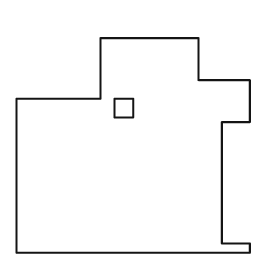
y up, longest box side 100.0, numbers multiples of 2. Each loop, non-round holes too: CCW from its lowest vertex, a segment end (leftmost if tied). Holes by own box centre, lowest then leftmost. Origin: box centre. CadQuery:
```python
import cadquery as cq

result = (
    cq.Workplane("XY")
    .moveTo(-50.0, -46.0)
    .lineTo(50.0, -46.0)
    .lineTo(50.0, -42.0)
    .lineTo(38.0, -42.0)
    .lineTo(38.0, 10.0)
    .lineTo(50.0, 10.0)
    .lineTo(50.0, 28.0)
    .lineTo(28.0, 28.0)
    .lineTo(28.0, 46.0)
    .lineTo(-14.0, 46.0)
    .lineTo(-14.0, 20.0)
    .lineTo(-50.0, 20.0)
    .close()
    .moveTo(-8.0, 12.0)
    .lineTo(0.0, 12.0)
    .lineTo(0.0, 20.0)
    .lineTo(-8.0, 20.0)
    .close()
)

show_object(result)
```